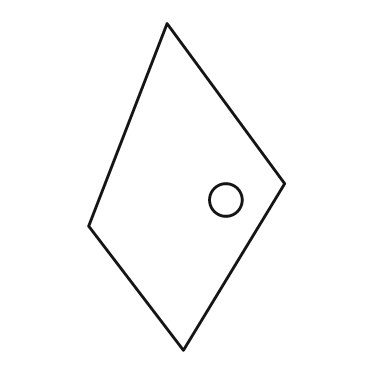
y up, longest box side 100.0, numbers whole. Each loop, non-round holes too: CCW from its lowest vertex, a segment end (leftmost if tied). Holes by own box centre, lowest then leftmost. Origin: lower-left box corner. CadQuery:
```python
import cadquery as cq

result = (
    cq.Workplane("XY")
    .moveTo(29.0, 0.0)
    .lineTo(60.0, 51.0)
    .lineTo(24.0, 100.0)
    .lineTo(0.0, 38.0)
    .close()
    .moveTo(42.0, 46.0)
    .circle(5.0)
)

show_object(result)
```